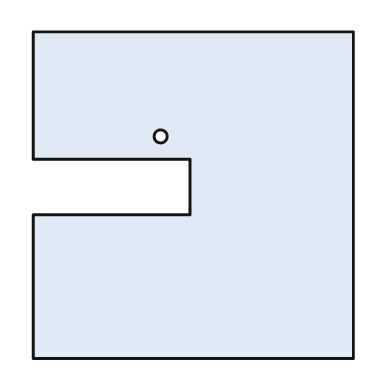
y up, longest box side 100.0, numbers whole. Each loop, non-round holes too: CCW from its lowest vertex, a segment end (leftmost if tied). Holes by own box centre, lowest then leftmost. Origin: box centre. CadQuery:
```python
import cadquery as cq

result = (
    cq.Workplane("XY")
    .moveTo(-49.0, -50.0)
    .lineTo(49.0, -50.0)
    .lineTo(49.0, 50.0)
    .lineTo(-49.0, 50.0)
    .lineTo(-49.0, 11.0)
    .lineTo(-1.0, 11.0)
    .lineTo(-1.0, -6.0)
    .lineTo(-49.0, -6.0)
    .close()
    .moveTo(-10.0, 18.0)
    .circle(2.0)
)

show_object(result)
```